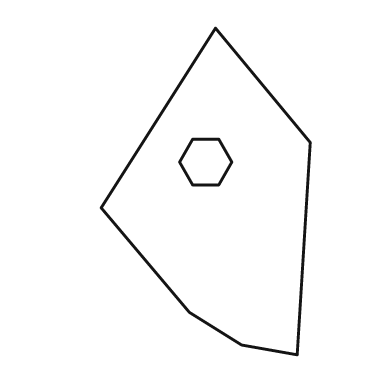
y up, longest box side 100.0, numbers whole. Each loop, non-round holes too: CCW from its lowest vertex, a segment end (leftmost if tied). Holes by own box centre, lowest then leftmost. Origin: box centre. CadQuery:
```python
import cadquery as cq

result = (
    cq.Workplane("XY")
    .moveTo(28.0, -50.0)
    .lineTo(32.0, 15.0)
    .lineTo(3.0, 50.0)
    .lineTo(-32.0, -5.0)
    .lineTo(-5.0, -37.0)
    .lineTo(11.0, -47.0)
    .close()
    .moveTo(-4.0, 2.0)
    .lineTo(4.0, 2.0)
    .lineTo(8.0, 9.0)
    .lineTo(4.0, 16.0)
    .lineTo(-4.0, 16.0)
    .lineTo(-8.0, 9.0)
    .close()
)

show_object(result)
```